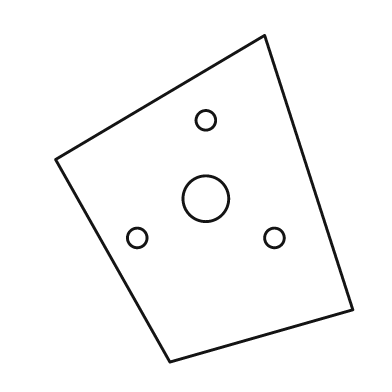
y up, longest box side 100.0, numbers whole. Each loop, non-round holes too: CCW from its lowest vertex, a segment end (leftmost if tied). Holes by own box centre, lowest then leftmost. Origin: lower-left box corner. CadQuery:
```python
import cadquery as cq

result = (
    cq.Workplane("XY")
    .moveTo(35.0, 0.0)
    .lineTo(91.0, 16.0)
    .lineTo(64.0, 100.0)
    .lineTo(0.0, 62.0)
    .close()
    .moveTo(25.0, 38.0)
    .circle(3.0)
    .moveTo(67.0, 38.0)
    .circle(3.0)
    .moveTo(46.0, 50.0)
    .circle(7.0)
    .moveTo(46.0, 74.0)
    .circle(3.0)
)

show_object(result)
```